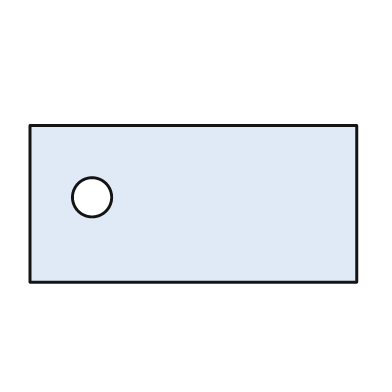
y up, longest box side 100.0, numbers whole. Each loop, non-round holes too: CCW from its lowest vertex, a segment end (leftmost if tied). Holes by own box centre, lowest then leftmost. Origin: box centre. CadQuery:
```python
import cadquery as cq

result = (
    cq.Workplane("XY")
    .moveTo(-50.0, -24.0)
    .lineTo(50.0, -24.0)
    .lineTo(50.0, 24.0)
    .lineTo(-50.0, 24.0)
    .close()
    .moveTo(-31.0, 2.0)
    .circle(6.0)
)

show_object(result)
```